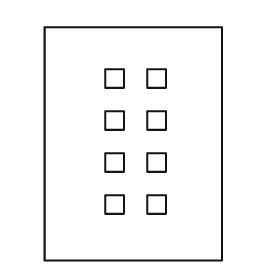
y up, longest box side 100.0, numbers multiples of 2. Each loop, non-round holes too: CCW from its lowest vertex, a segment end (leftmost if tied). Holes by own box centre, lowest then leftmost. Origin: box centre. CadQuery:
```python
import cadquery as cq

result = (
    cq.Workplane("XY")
    .moveTo(-38.0, -50.0)
    .lineTo(38.0, -50.0)
    .lineTo(38.0, 50.0)
    .lineTo(-38.0, 50.0)
    .close()
    .moveTo(-12.0, -30.0)
    .lineTo(-4.0, -30.0)
    .lineTo(-4.0, -22.0)
    .lineTo(-12.0, -22.0)
    .close()
    .moveTo(6.0, -30.0)
    .lineTo(14.0, -30.0)
    .lineTo(14.0, -22.0)
    .lineTo(6.0, -22.0)
    .close()
    .moveTo(-12.0, -12.0)
    .lineTo(-4.0, -12.0)
    .lineTo(-4.0, -4.0)
    .lineTo(-12.0, -4.0)
    .close()
    .moveTo(6.0, -12.0)
    .lineTo(14.0, -12.0)
    .lineTo(14.0, -4.0)
    .lineTo(6.0, -4.0)
    .close()
    .moveTo(-12.0, 6.0)
    .lineTo(-4.0, 6.0)
    .lineTo(-4.0, 14.0)
    .lineTo(-12.0, 14.0)
    .close()
    .moveTo(6.0, 6.0)
    .lineTo(14.0, 6.0)
    .lineTo(14.0, 14.0)
    .lineTo(6.0, 14.0)
    .close()
    .moveTo(-12.0, 24.0)
    .lineTo(-4.0, 24.0)
    .lineTo(-4.0, 32.0)
    .lineTo(-12.0, 32.0)
    .close()
    .moveTo(6.0, 24.0)
    .lineTo(14.0, 24.0)
    .lineTo(14.0, 32.0)
    .lineTo(6.0, 32.0)
    .close()
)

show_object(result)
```